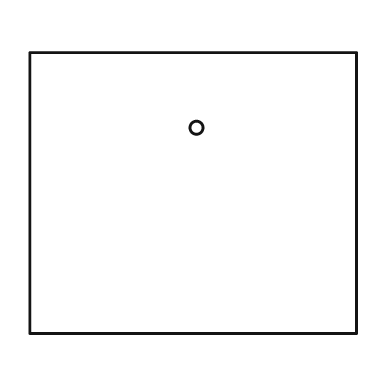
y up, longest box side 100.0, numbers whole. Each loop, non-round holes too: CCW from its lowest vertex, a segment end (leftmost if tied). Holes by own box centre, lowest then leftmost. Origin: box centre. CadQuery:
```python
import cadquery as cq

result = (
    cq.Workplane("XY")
    .moveTo(-50.0, -43.0)
    .lineTo(50.0, -43.0)
    .lineTo(50.0, 43.0)
    .lineTo(-50.0, 43.0)
    .close()
    .moveTo(1.0, 20.0)
    .circle(2.0)
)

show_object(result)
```